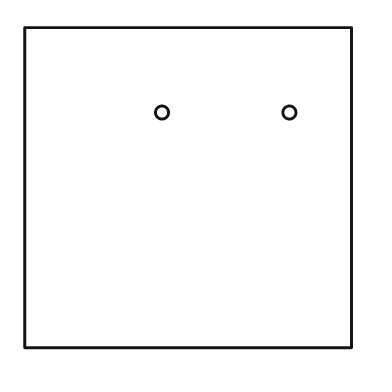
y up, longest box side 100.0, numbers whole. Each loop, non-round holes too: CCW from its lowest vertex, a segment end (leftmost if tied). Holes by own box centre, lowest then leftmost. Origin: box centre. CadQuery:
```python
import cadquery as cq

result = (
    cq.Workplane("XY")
    .moveTo(-50.0, -49.0)
    .lineTo(50.0, -49.0)
    .lineTo(50.0, 49.0)
    .lineTo(-50.0, 49.0)
    .close()
    .moveTo(-8.0, 23.0)
    .circle(2.0)
    .moveTo(31.0, 23.0)
    .circle(2.0)
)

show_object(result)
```